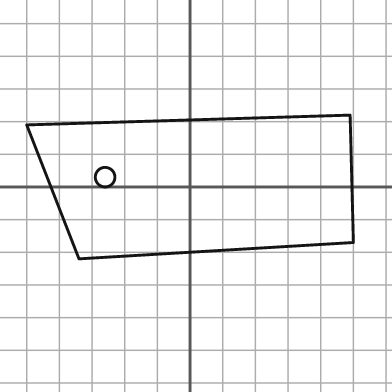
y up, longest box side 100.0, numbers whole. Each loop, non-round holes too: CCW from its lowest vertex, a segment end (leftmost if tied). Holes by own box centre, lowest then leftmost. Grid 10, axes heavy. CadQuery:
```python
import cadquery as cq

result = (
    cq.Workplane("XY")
    .moveTo(-34.0, -22.0)
    .lineTo(50.0, -17.0)
    .lineTo(49.0, 22.0)
    .lineTo(-50.0, 19.0)
    .close()
    .moveTo(-26.0, 3.0)
    .circle(3.0)
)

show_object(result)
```